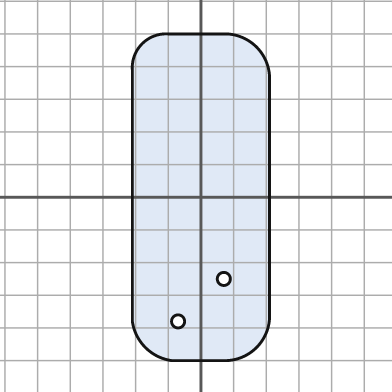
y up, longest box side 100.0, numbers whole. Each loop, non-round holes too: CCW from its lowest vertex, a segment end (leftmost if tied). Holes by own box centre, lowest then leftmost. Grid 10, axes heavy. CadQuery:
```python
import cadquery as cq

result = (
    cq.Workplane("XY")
    .moveTo(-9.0, -50.0)
    .lineTo(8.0, -50.0)
    .threePointArc((17.0, -46.0), (21.0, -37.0))
    .lineTo(21.0, 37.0)
    .threePointArc((17.0, 46.0), (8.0, 50.0))
    .lineTo(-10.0, 50.0)
    .threePointArc((-18.0, 47.0), (-21.0, 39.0))
    .lineTo(-21.0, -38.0)
    .threePointArc((-17.0, -46.0), (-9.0, -50.0))
    .close()
    .moveTo(-7.0, -38.0)
    .circle(2.0)
    .moveTo(7.0, -25.0)
    .circle(2.0)
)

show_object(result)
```